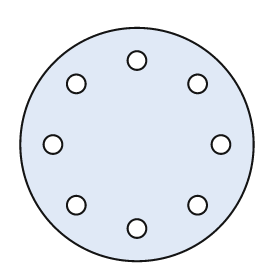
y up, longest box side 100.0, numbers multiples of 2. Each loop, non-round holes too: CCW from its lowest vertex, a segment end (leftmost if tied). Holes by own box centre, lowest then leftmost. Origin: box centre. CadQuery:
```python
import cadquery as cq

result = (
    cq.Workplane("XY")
    .moveTo(0.0, 0.0)
    .circle(50.0)
    .moveTo(0.0, -36.0)
    .circle(4.0)
    .moveTo(-26.0, -26.0)
    .circle(4.0)
    .moveTo(26.0, -26.0)
    .circle(4.0)
    .moveTo(-36.0, 0.0)
    .circle(4.0)
    .moveTo(36.0, 0.0)
    .circle(4.0)
    .moveTo(-26.0, 26.0)
    .circle(4.0)
    .moveTo(26.0, 26.0)
    .circle(4.0)
    .moveTo(0.0, 36.0)
    .circle(4.0)
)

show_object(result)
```